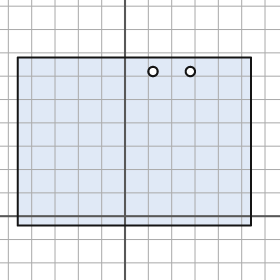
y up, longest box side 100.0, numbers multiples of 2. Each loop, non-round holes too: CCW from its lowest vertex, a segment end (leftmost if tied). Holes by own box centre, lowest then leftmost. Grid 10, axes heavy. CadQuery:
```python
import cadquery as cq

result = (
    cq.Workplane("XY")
    .moveTo(-46.0, -4.0)
    .lineTo(54.0, -4.0)
    .lineTo(54.0, 68.0)
    .lineTo(-46.0, 68.0)
    .close()
    .moveTo(12.0, 62.0)
    .circle(2.0)
    .moveTo(28.0, 62.0)
    .circle(2.0)
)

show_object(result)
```